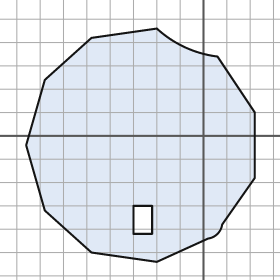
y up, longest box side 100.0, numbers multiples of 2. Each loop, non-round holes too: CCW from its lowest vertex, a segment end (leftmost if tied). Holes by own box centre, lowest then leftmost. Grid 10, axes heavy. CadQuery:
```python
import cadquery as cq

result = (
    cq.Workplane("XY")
    .moveTo(-20.0, -54.0)
    .lineTo(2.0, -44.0)
    .threePointArc((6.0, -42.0), (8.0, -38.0))
    .lineTo(22.0, -18.0)
    .lineTo(22.0, 10.0)
    .lineTo(6.0, 34.0)
    .threePointArc((-8.0, 38.0), (-20.0, 46.0))
    .lineTo(-48.0, 42.0)
    .lineTo(-68.0, 24.0)
    .lineTo(-76.0, -4.0)
    .lineTo(-68.0, -32.0)
    .lineTo(-48.0, -50.0)
    .close()
    .moveTo(-30.0, -42.0)
    .lineTo(-22.0, -42.0)
    .lineTo(-22.0, -30.0)
    .lineTo(-30.0, -30.0)
    .close()
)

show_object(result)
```